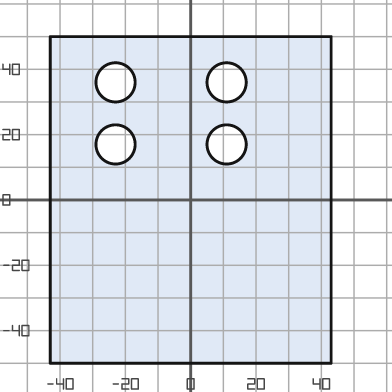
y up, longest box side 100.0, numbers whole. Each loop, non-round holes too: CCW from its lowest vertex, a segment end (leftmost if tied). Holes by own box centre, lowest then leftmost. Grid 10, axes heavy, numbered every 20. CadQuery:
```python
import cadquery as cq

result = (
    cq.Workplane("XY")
    .moveTo(-43.0, -50.0)
    .lineTo(43.0, -50.0)
    .lineTo(43.0, 50.0)
    .lineTo(-43.0, 50.0)
    .close()
    .moveTo(-23.0, 17.0)
    .circle(6.0)
    .moveTo(11.0, 17.0)
    .circle(6.0)
    .moveTo(-23.0, 36.0)
    .circle(6.0)
    .moveTo(11.0, 36.0)
    .circle(6.0)
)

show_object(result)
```